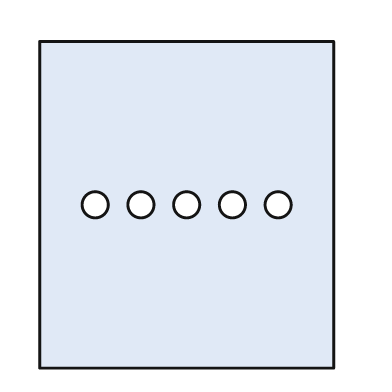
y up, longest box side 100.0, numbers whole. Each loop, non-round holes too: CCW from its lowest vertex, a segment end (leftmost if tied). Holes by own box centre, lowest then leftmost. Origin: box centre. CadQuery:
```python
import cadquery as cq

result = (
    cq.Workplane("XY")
    .moveTo(-45.0, -50.0)
    .lineTo(45.0, -50.0)
    .lineTo(45.0, 50.0)
    .lineTo(-45.0, 50.0)
    .close()
    .moveTo(-28.0, 0.0)
    .circle(4.0)
    .moveTo(-14.0, 0.0)
    .circle(4.0)
    .moveTo(0.0, 0.0)
    .circle(4.0)
    .moveTo(14.0, 0.0)
    .circle(4.0)
    .moveTo(28.0, 0.0)
    .circle(4.0)
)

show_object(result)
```